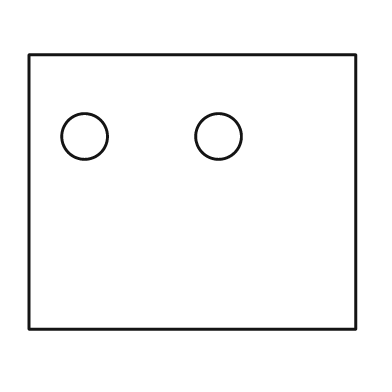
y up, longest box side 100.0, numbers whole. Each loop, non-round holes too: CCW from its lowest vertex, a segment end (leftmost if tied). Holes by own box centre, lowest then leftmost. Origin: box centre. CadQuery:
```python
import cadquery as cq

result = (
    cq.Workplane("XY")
    .moveTo(-50.0, -42.0)
    .lineTo(50.0, -42.0)
    .lineTo(50.0, 42.0)
    .lineTo(-50.0, 42.0)
    .close()
    .moveTo(-33.0, 17.0)
    .circle(7.0)
    .moveTo(8.0, 17.0)
    .circle(7.0)
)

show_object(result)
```